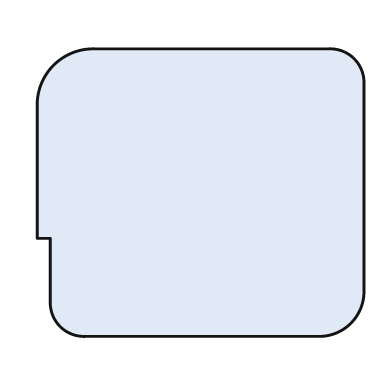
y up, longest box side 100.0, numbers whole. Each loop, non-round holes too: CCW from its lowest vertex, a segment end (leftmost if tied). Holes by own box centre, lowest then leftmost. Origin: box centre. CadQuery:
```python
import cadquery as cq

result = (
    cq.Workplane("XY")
    .moveTo(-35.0, -44.0)
    .lineTo(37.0, -44.0)
    .threePointArc((46.0, -40.0), (50.0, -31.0))
    .lineTo(50.0, 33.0)
    .threePointArc((47.0, 41.0), (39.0, 44.0))
    .lineTo(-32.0, 44.0)
    .threePointArc((-45.0, 39.0), (-50.0, 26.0))
    .lineTo(-50.0, -14.0)
    .lineTo(-46.0, -14.0)
    .lineTo(-46.0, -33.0)
    .threePointArc((-43.0, -41.0), (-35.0, -44.0))
    .close()
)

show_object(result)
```